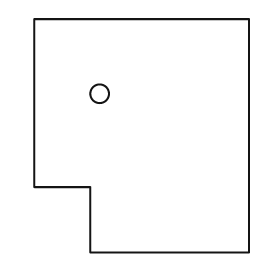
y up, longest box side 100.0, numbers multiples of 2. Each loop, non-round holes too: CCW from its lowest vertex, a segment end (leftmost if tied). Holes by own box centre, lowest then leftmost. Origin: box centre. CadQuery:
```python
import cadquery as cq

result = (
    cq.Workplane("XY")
    .moveTo(-22.0, -50.0)
    .lineTo(46.0, -50.0)
    .lineTo(46.0, 50.0)
    .lineTo(-46.0, 50.0)
    .lineTo(-46.0, -22.0)
    .lineTo(-22.0, -22.0)
    .close()
    .moveTo(-18.0, 18.0)
    .circle(4.0)
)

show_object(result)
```